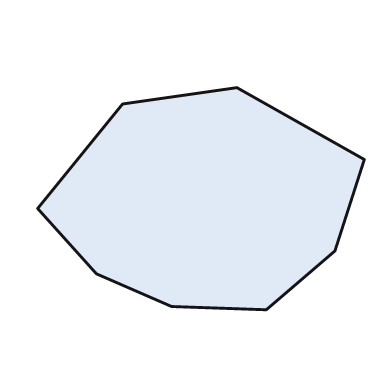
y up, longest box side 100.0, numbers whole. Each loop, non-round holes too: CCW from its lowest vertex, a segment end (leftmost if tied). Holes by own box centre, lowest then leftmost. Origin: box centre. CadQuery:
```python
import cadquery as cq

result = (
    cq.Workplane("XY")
    .moveTo(20.0, -34.0)
    .lineTo(41.0, -16.0)
    .lineTo(50.0, 12.0)
    .lineTo(11.0, 34.0)
    .lineTo(-24.0, 29.0)
    .lineTo(-50.0, -3.0)
    .lineTo(-32.0, -23.0)
    .lineTo(-9.0, -33.0)
    .close()
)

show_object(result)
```